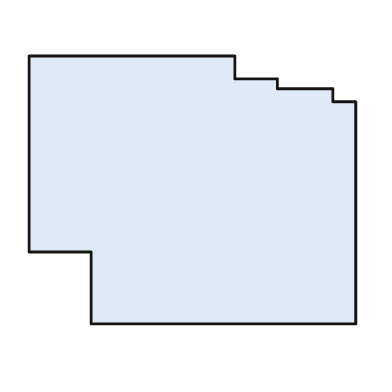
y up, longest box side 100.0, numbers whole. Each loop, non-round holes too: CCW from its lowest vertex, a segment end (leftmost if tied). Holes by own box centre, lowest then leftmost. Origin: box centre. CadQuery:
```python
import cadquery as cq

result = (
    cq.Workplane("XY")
    .moveTo(-31.0, -41.0)
    .lineTo(50.0, -41.0)
    .lineTo(50.0, 27.0)
    .lineTo(43.0, 27.0)
    .lineTo(43.0, 31.0)
    .lineTo(26.0, 31.0)
    .lineTo(26.0, 34.0)
    .lineTo(13.0, 34.0)
    .lineTo(13.0, 41.0)
    .lineTo(-50.0, 41.0)
    .lineTo(-50.0, -19.0)
    .lineTo(-31.0, -19.0)
    .close()
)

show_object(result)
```